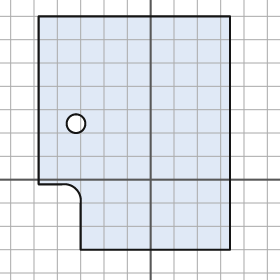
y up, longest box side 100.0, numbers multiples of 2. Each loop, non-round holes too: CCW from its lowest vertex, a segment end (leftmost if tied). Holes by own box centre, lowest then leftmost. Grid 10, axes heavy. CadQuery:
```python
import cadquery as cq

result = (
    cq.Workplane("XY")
    .moveTo(-30.0, -30.0)
    .lineTo(34.0, -30.0)
    .lineTo(34.0, 70.0)
    .lineTo(-48.0, 70.0)
    .lineTo(-48.0, -2.0)
    .lineTo(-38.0, -2.0)
    .threePointArc((-32.0, -4.0), (-30.0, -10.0))
    .close()
    .moveTo(-32.0, 24.0)
    .circle(4.0)
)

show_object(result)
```